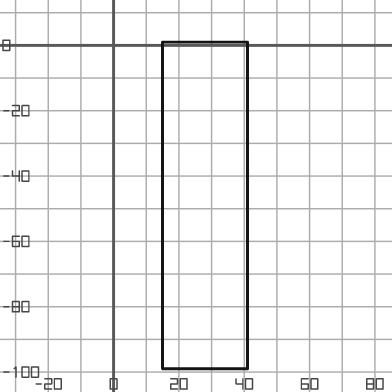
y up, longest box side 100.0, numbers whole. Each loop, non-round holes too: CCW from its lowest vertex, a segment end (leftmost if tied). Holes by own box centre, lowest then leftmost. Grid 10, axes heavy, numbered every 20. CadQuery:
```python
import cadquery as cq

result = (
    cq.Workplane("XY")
    .moveTo(15.0, -99.0)
    .lineTo(41.0, -99.0)
    .lineTo(41.0, 1.0)
    .lineTo(15.0, 1.0)
    .close()
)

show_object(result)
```